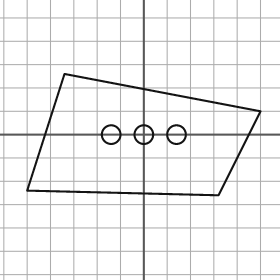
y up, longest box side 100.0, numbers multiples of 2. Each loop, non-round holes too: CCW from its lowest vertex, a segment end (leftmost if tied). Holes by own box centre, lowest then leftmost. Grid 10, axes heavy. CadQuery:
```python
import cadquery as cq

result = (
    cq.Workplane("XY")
    .moveTo(32.0, -26.0)
    .lineTo(50.0, 10.0)
    .lineTo(-34.0, 26.0)
    .lineTo(-50.0, -24.0)
    .close()
    .moveTo(-14.0, 0.0)
    .circle(4.0)
    .moveTo(0.0, 0.0)
    .circle(4.0)
    .moveTo(14.0, 0.0)
    .circle(4.0)
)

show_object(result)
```